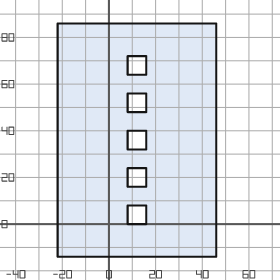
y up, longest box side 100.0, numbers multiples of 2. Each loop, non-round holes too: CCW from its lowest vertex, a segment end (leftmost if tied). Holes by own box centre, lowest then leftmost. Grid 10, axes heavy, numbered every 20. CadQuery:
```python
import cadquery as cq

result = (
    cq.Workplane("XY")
    .moveTo(-22.0, -14.0)
    .lineTo(46.0, -14.0)
    .lineTo(46.0, 86.0)
    .lineTo(-22.0, 86.0)
    .close()
    .moveTo(8.0, 0.0)
    .lineTo(16.0, 0.0)
    .lineTo(16.0, 8.0)
    .lineTo(8.0, 8.0)
    .close()
    .moveTo(8.0, 16.0)
    .lineTo(16.0, 16.0)
    .lineTo(16.0, 24.0)
    .lineTo(8.0, 24.0)
    .close()
    .moveTo(8.0, 32.0)
    .lineTo(16.0, 32.0)
    .lineTo(16.0, 40.0)
    .lineTo(8.0, 40.0)
    .close()
    .moveTo(8.0, 48.0)
    .lineTo(16.0, 48.0)
    .lineTo(16.0, 56.0)
    .lineTo(8.0, 56.0)
    .close()
    .moveTo(8.0, 64.0)
    .lineTo(16.0, 64.0)
    .lineTo(16.0, 72.0)
    .lineTo(8.0, 72.0)
    .close()
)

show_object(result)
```